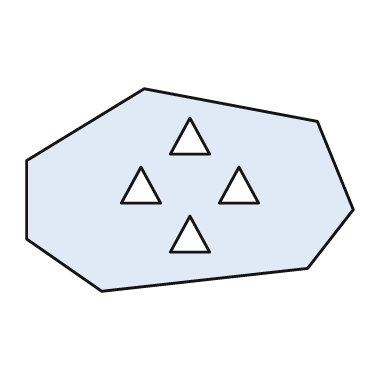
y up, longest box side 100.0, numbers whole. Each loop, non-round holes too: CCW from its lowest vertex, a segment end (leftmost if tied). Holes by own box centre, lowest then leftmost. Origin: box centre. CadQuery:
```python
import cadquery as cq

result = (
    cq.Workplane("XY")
    .moveTo(-27.0, -31.0)
    .lineTo(36.0, -24.0)
    .lineTo(50.0, -6.0)
    .lineTo(39.0, 21.0)
    .lineTo(-14.0, 31.0)
    .lineTo(-50.0, 9.0)
    .lineTo(-50.0, -15.0)
    .close()
    .moveTo(-6.0, -19.0)
    .lineTo(6.0, -19.0)
    .lineTo(0.0, -8.0)
    .close()
    .moveTo(-21.0, -4.0)
    .lineTo(-9.0, -4.0)
    .lineTo(-15.0, 7.0)
    .close()
    .moveTo(9.0, -4.0)
    .lineTo(21.0, -4.0)
    .lineTo(15.0, 7.0)
    .close()
    .moveTo(-6.0, 11.0)
    .lineTo(6.0, 11.0)
    .lineTo(0.0, 22.0)
    .close()
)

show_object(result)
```